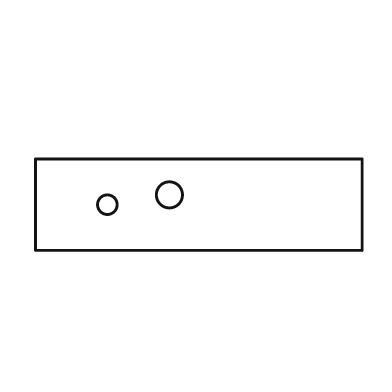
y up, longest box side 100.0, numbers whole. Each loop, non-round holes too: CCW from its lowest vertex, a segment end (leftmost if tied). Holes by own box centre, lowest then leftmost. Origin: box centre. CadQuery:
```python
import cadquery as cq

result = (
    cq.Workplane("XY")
    .moveTo(-50.0, -14.0)
    .lineTo(50.0, -14.0)
    .lineTo(50.0, 14.0)
    .lineTo(-50.0, 14.0)
    .close()
    .moveTo(-28.0, 0.0)
    .circle(3.0)
    .moveTo(-9.0, 3.0)
    .circle(4.0)
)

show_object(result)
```